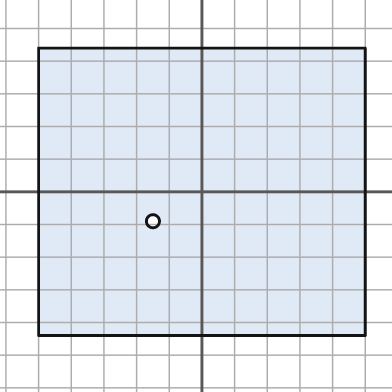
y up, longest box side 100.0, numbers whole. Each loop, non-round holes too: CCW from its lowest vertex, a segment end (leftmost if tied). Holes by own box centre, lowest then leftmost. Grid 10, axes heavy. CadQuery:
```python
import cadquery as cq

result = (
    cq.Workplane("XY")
    .moveTo(-50.0, -44.0)
    .lineTo(50.0, -44.0)
    .lineTo(50.0, 44.0)
    .lineTo(-50.0, 44.0)
    .close()
    .moveTo(-15.0, -9.0)
    .circle(2.0)
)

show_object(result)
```